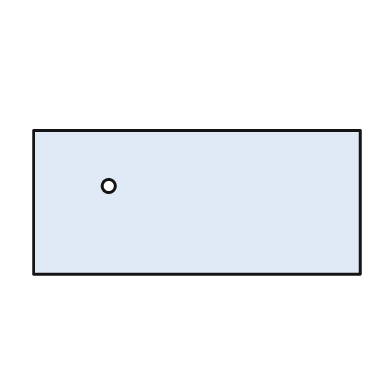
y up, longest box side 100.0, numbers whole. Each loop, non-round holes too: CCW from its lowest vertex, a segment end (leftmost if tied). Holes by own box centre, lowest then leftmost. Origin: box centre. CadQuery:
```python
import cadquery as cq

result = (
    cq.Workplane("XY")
    .moveTo(-50.0, -22.0)
    .lineTo(50.0, -22.0)
    .lineTo(50.0, 22.0)
    .lineTo(-50.0, 22.0)
    .close()
    .moveTo(-27.0, 5.0)
    .circle(2.0)
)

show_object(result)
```